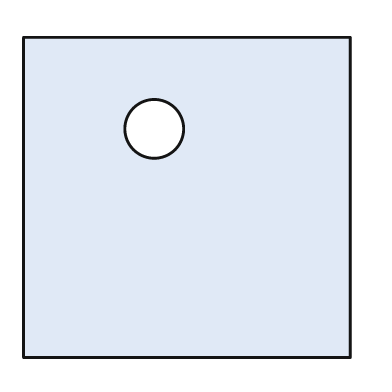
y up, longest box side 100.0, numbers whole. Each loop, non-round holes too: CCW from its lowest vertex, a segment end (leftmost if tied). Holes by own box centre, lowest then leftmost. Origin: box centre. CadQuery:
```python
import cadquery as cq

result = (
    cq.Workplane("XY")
    .moveTo(-50.0, -49.0)
    .lineTo(50.0, -49.0)
    .lineTo(50.0, 49.0)
    .lineTo(-50.0, 49.0)
    .close()
    .moveTo(-10.0, 21.0)
    .circle(9.0)
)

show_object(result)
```